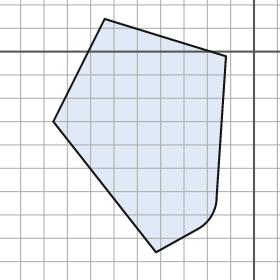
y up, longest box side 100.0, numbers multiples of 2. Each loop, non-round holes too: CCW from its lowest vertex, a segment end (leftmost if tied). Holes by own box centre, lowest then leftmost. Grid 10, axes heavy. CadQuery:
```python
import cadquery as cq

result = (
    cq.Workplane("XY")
    .moveTo(-42.0, -86.0)
    .lineTo(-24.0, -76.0)
    .threePointArc((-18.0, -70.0), (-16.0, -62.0))
    .lineTo(-12.0, -2.0)
    .lineTo(-64.0, 14.0)
    .lineTo(-86.0, -30.0)
    .close()
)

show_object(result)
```